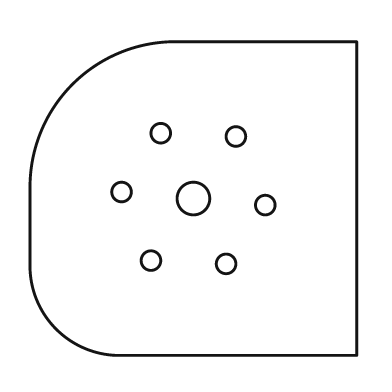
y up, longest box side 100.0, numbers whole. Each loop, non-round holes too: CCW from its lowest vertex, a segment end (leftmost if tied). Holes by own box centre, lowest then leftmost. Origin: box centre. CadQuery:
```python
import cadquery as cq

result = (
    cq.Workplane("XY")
    .moveTo(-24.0, -48.0)
    .lineTo(50.0, -48.0)
    .lineTo(50.0, 48.0)
    .lineTo(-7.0, 48.0)
    .threePointArc((-37.0, 35.0), (-50.0, 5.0))
    .lineTo(-50.0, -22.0)
    .threePointArc((-42.0, -40.0), (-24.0, -48.0))
    .close()
    .moveTo(10.0, -20.0)
    .circle(3.0)
    .moveTo(-13.0, -19.0)
    .circle(3.0)
    .moveTo(22.0, -2.0)
    .circle(3.0)
    .moveTo(0.0, 0.0)
    .circle(5.0)
    .moveTo(-22.0, 2.0)
    .circle(3.0)
    .moveTo(13.0, 19.0)
    .circle(3.0)
    .moveTo(-10.0, 20.0)
    .circle(3.0)
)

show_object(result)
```